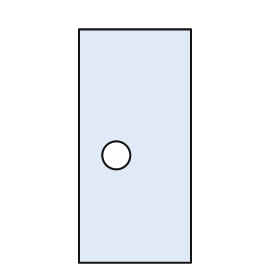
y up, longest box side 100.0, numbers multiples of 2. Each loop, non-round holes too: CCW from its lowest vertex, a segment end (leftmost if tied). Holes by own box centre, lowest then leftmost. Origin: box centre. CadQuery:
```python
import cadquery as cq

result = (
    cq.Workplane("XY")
    .moveTo(-24.0, -50.0)
    .lineTo(24.0, -50.0)
    .lineTo(24.0, 50.0)
    .lineTo(-24.0, 50.0)
    .close()
    .moveTo(-8.0, -4.0)
    .circle(6.0)
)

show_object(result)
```